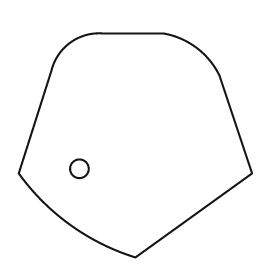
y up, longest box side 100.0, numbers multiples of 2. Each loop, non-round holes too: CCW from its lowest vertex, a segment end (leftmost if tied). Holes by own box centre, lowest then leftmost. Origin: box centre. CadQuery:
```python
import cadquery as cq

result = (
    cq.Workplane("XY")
    .moveTo(0.0, -48.0)
    .lineTo(50.0, -12.0)
    .lineTo(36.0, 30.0)
    .threePointArc((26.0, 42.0), (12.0, 48.0))
    .lineTo(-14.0, 48.0)
    .threePointArc((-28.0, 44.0), (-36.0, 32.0))
    .lineTo(-50.0, -12.0)
    .threePointArc((-28.0, -34.0), (0.0, -48.0))
    .close()
    .moveTo(-24.0, -10.0)
    .circle(4.0)
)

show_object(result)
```